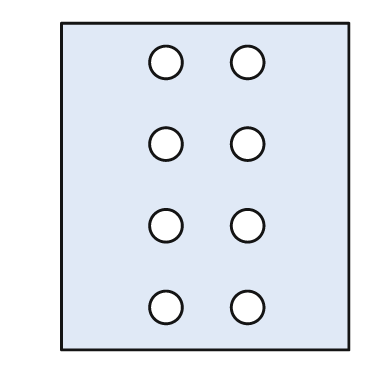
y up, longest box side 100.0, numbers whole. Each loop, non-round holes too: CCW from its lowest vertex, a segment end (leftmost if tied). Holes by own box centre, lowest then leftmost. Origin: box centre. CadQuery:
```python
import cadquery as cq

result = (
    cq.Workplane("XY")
    .moveTo(-44.0, -50.0)
    .lineTo(44.0, -50.0)
    .lineTo(44.0, 50.0)
    .lineTo(-44.0, 50.0)
    .close()
    .moveTo(-12.0, -37.0)
    .circle(5.0)
    .moveTo(13.0, -37.0)
    .circle(5.0)
    .moveTo(-12.0, -12.0)
    .circle(5.0)
    .moveTo(13.0, -12.0)
    .circle(5.0)
    .moveTo(-12.0, 13.0)
    .circle(5.0)
    .moveTo(13.0, 13.0)
    .circle(5.0)
    .moveTo(-12.0, 38.0)
    .circle(5.0)
    .moveTo(13.0, 38.0)
    .circle(5.0)
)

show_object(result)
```